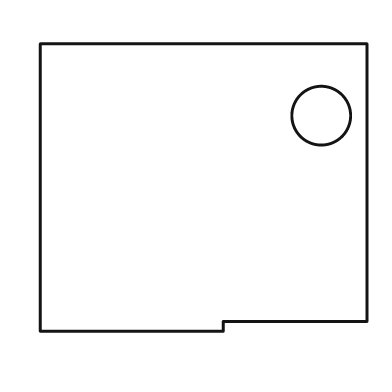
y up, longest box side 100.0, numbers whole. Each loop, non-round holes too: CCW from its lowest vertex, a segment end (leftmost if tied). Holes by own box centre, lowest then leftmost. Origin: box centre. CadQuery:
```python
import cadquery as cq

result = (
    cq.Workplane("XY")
    .moveTo(-50.0, -44.0)
    .lineTo(6.0, -44.0)
    .lineTo(6.0, -41.0)
    .lineTo(50.0, -41.0)
    .lineTo(50.0, 44.0)
    .lineTo(-50.0, 44.0)
    .close()
    .moveTo(36.0, 22.0)
    .circle(9.0)
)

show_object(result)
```